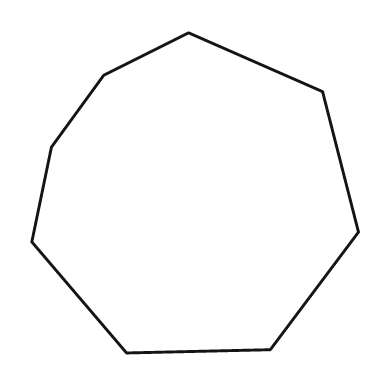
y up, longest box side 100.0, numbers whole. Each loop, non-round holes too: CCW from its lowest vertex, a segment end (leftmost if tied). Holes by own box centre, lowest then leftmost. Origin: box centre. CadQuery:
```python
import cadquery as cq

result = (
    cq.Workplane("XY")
    .moveTo(-21.0, -49.0)
    .lineTo(23.0, -48.0)
    .lineTo(50.0, -12.0)
    .lineTo(39.0, 31.0)
    .lineTo(-2.0, 49.0)
    .lineTo(-28.0, 36.0)
    .lineTo(-44.0, 14.0)
    .lineTo(-50.0, -15.0)
    .close()
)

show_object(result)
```